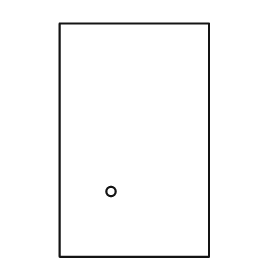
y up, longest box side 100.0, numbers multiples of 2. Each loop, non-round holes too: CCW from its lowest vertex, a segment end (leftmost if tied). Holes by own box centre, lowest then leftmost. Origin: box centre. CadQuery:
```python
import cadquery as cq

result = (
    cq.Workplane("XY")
    .moveTo(-32.0, -50.0)
    .lineTo(32.0, -50.0)
    .lineTo(32.0, 50.0)
    .lineTo(-32.0, 50.0)
    .close()
    .moveTo(-10.0, -22.0)
    .circle(2.0)
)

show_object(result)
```